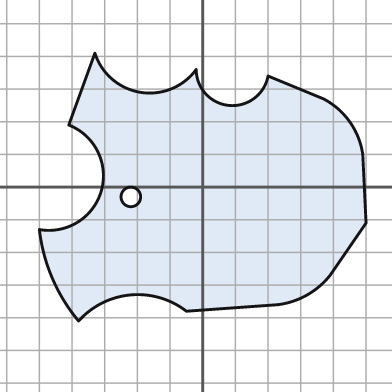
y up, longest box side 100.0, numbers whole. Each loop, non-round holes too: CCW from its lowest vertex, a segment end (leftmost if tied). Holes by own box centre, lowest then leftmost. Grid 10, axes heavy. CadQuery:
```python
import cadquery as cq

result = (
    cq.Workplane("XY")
    .moveTo(-38.0, -41.0)
    .threePointArc((-22.0, -33.0), (-5.0, -38.0))
    .lineTo(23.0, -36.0)
    .threePointArc((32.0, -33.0), (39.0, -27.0))
    .lineTo(50.0, -11.0)
    .lineTo(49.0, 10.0)
    .threePointArc((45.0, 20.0), (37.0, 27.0))
    .lineTo(20.0, 34.0)
    .threePointArc((8.0, 25.0), (-2.0, 36.0))
    .threePointArc((-19.0, 29.0), (-33.0, 41.0))
    .lineTo(-41.0, 19.0)
    .threePointArc((-31.0, -1.0), (-50.0, -13.0))
    .threePointArc((-46.0, -28.0), (-38.0, -41.0))
    .close()
    .moveTo(-22.0, -3.0)
    .circle(3.0)
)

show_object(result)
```